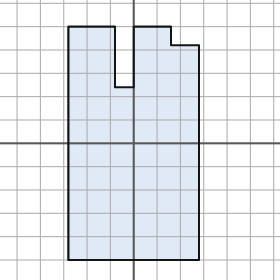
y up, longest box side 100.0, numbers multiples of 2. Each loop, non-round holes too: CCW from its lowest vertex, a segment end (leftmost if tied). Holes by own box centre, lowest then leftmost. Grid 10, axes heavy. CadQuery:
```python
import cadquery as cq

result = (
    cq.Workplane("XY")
    .moveTo(-28.0, -50.0)
    .lineTo(28.0, -50.0)
    .lineTo(28.0, 42.0)
    .lineTo(16.0, 42.0)
    .lineTo(16.0, 50.0)
    .lineTo(0.0, 50.0)
    .lineTo(0.0, 24.0)
    .lineTo(-8.0, 24.0)
    .lineTo(-8.0, 50.0)
    .lineTo(-28.0, 50.0)
    .close()
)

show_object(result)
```